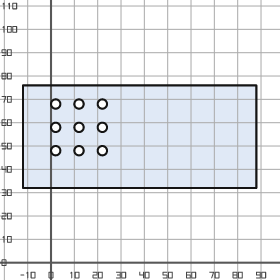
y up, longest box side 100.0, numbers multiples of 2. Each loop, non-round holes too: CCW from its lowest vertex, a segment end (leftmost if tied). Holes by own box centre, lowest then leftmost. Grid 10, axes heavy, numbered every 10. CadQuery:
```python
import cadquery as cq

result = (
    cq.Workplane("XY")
    .moveTo(-12.0, 32.0)
    .lineTo(88.0, 32.0)
    .lineTo(88.0, 76.0)
    .lineTo(-12.0, 76.0)
    .close()
    .moveTo(2.0, 48.0)
    .circle(2.0)
    .moveTo(12.0, 48.0)
    .circle(2.0)
    .moveTo(22.0, 48.0)
    .circle(2.0)
    .moveTo(2.0, 58.0)
    .circle(2.0)
    .moveTo(12.0, 58.0)
    .circle(2.0)
    .moveTo(22.0, 58.0)
    .circle(2.0)
    .moveTo(2.0, 68.0)
    .circle(2.0)
    .moveTo(12.0, 68.0)
    .circle(2.0)
    .moveTo(22.0, 68.0)
    .circle(2.0)
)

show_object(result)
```